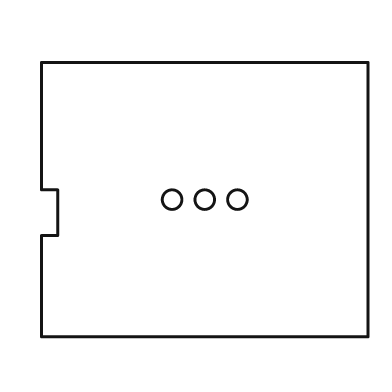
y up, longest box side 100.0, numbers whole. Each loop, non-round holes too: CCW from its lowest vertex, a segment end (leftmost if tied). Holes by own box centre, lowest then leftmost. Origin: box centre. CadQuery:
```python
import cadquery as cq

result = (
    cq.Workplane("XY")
    .moveTo(-50.0, -42.0)
    .lineTo(50.0, -42.0)
    .lineTo(50.0, 42.0)
    .lineTo(-50.0, 42.0)
    .lineTo(-50.0, 3.0)
    .lineTo(-45.0, 3.0)
    .lineTo(-45.0, -11.0)
    .lineTo(-50.0, -11.0)
    .close()
    .moveTo(-10.0, 0.0)
    .circle(3.0)
    .moveTo(0.0, 0.0)
    .circle(3.0)
    .moveTo(10.0, 0.0)
    .circle(3.0)
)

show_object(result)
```